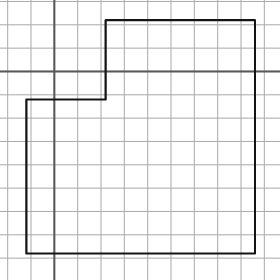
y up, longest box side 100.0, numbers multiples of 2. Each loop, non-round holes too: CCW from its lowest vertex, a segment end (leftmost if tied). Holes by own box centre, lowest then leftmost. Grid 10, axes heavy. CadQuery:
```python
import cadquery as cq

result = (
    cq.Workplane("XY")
    .moveTo(-12.0, -78.0)
    .lineTo(86.0, -78.0)
    .lineTo(86.0, 22.0)
    .lineTo(22.0, 22.0)
    .lineTo(22.0, -12.0)
    .lineTo(-12.0, -12.0)
    .close()
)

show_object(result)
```